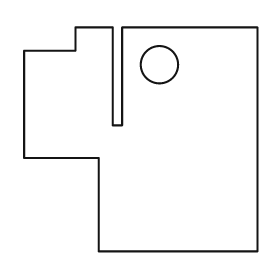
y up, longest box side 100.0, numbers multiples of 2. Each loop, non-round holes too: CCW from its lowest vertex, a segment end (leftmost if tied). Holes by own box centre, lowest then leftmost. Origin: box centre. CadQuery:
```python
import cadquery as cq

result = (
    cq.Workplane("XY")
    .moveTo(-18.0, -48.0)
    .lineTo(50.0, -48.0)
    .lineTo(50.0, 48.0)
    .lineTo(-8.0, 48.0)
    .lineTo(-8.0, 6.0)
    .lineTo(-12.0, 6.0)
    .lineTo(-12.0, 48.0)
    .lineTo(-28.0, 48.0)
    .lineTo(-28.0, 38.0)
    .lineTo(-50.0, 38.0)
    .lineTo(-50.0, -8.0)
    .lineTo(-18.0, -8.0)
    .close()
    .moveTo(8.0, 32.0)
    .circle(8.0)
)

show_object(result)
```